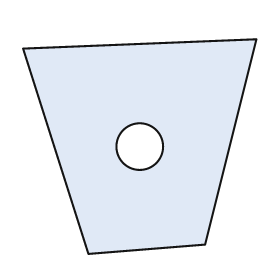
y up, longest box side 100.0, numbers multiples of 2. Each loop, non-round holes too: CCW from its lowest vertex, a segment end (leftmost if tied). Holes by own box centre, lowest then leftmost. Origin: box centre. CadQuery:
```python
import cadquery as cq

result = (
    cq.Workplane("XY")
    .moveTo(-22.0, -46.0)
    .lineTo(28.0, -42.0)
    .lineTo(50.0, 46.0)
    .lineTo(-50.0, 42.0)
    .close()
    .moveTo(0.0, 0.0)
    .circle(10.0)
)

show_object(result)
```